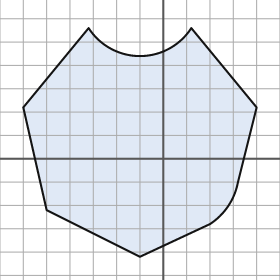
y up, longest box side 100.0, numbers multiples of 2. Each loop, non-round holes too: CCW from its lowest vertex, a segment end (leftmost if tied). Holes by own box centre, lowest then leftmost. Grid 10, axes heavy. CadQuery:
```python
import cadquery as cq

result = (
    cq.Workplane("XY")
    .moveTo(-10.0, -42.0)
    .lineTo(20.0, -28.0)
    .threePointArc((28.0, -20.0), (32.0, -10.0))
    .lineTo(40.0, 22.0)
    .lineTo(12.0, 56.0)
    .threePointArc((-10.0, 44.0), (-32.0, 56.0))
    .lineTo(-60.0, 22.0)
    .lineTo(-50.0, -22.0)
    .close()
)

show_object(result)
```